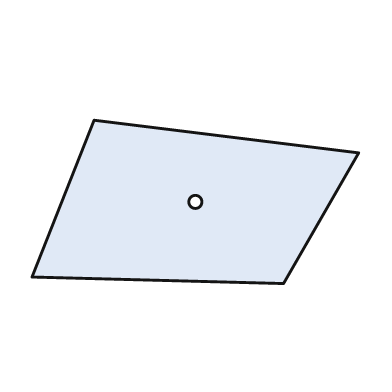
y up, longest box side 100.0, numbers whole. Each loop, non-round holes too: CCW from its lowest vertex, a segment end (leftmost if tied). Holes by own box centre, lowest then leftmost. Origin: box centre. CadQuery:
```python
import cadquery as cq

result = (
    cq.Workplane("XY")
    .moveTo(27.0, -25.0)
    .lineTo(50.0, 15.0)
    .lineTo(-31.0, 25.0)
    .lineTo(-50.0, -23.0)
    .close()
    .moveTo(0.0, 0.0)
    .circle(2.0)
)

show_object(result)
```